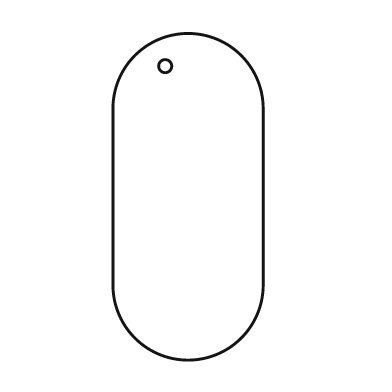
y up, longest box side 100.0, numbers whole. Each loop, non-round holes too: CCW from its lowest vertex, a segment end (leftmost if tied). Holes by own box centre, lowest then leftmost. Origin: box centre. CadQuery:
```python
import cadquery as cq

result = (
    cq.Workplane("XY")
    .moveTo(-23.0, -27.0)
    .threePointArc((0.0, -50.0), (23.0, -27.0))
    .lineTo(23.0, 27.0)
    .threePointArc((0.0, 50.0), (-23.0, 27.0))
    .close()
    .moveTo(-7.0, 40.0)
    .circle(2.0)
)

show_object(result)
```